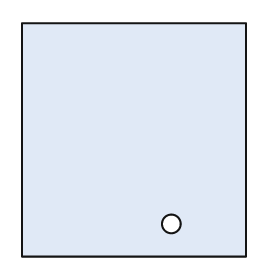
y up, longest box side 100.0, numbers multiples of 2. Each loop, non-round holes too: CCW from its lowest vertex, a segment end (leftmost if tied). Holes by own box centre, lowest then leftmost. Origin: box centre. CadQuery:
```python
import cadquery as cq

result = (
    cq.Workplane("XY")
    .moveTo(-48.0, -50.0)
    .lineTo(48.0, -50.0)
    .lineTo(48.0, 50.0)
    .lineTo(-48.0, 50.0)
    .close()
    .moveTo(16.0, -36.0)
    .circle(4.0)
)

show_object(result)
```